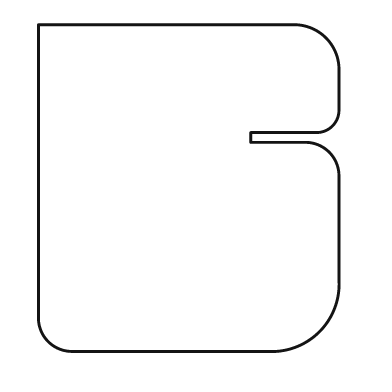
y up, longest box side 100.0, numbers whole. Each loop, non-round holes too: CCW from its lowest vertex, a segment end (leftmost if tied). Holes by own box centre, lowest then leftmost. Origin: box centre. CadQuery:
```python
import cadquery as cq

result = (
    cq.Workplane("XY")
    .moveTo(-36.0, -50.0)
    .lineTo(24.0, -50.0)
    .threePointArc((40.0, -44.0), (46.0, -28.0))
    .lineTo(46.0, 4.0)
    .threePointArc((43.0, 11.0), (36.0, 14.0))
    .lineTo(19.0, 14.0)
    .lineTo(19.0, 17.0)
    .lineTo(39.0, 17.0)
    .threePointArc((44.0, 19.0), (46.0, 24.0))
    .lineTo(46.0, 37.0)
    .threePointArc((42.0, 46.0), (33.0, 50.0))
    .lineTo(-46.0, 50.0)
    .lineTo(-46.0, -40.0)
    .threePointArc((-43.0, -47.0), (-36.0, -50.0))
    .close()
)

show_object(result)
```